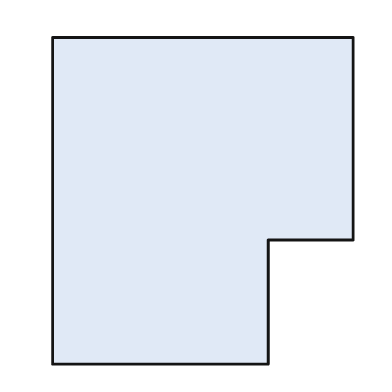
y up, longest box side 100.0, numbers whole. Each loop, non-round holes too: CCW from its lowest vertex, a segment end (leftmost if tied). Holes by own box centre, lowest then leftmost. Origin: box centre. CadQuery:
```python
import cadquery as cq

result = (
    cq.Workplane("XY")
    .moveTo(-46.0, -50.0)
    .lineTo(20.0, -50.0)
    .lineTo(20.0, -12.0)
    .lineTo(46.0, -12.0)
    .lineTo(46.0, 50.0)
    .lineTo(-46.0, 50.0)
    .close()
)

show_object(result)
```